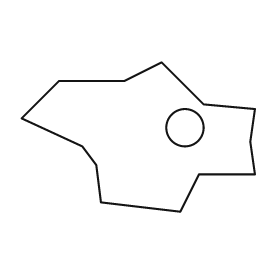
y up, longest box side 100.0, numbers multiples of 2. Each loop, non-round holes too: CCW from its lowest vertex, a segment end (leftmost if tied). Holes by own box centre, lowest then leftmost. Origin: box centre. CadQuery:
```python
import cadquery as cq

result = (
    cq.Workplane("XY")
    .moveTo(18.0, -32.0)
    .lineTo(26.0, -16.0)
    .lineTo(50.0, -16.0)
    .lineTo(48.0, -2.0)
    .lineTo(50.0, 12.0)
    .lineTo(28.0, 14.0)
    .lineTo(10.0, 32.0)
    .lineTo(-6.0, 24.0)
    .lineTo(-34.0, 24.0)
    .lineTo(-50.0, 8.0)
    .lineTo(-24.0, -4.0)
    .lineTo(-18.0, -12.0)
    .lineTo(-16.0, -28.0)
    .close()
    .moveTo(20.0, 4.0)
    .circle(8.0)
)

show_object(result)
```